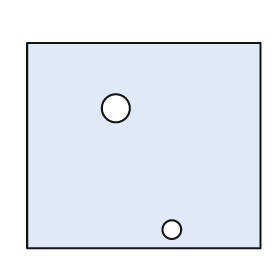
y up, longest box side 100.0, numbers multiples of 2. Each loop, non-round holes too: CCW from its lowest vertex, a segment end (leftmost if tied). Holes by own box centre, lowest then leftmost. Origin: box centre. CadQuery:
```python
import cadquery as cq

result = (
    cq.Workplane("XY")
    .moveTo(-50.0, -44.0)
    .lineTo(50.0, -44.0)
    .lineTo(50.0, 44.0)
    .lineTo(-50.0, 44.0)
    .close()
    .moveTo(12.0, -36.0)
    .circle(4.0)
    .moveTo(-12.0, 16.0)
    .circle(6.0)
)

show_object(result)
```